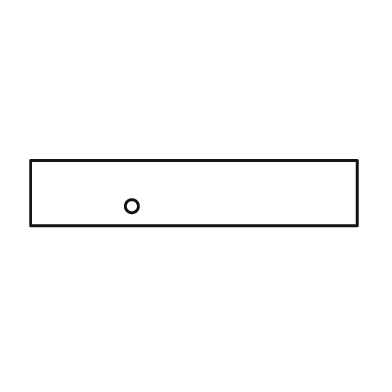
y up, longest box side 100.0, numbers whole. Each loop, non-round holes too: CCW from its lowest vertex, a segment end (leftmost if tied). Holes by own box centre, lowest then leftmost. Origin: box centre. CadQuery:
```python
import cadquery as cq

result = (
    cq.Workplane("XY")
    .moveTo(-50.0, -10.0)
    .lineTo(50.0, -10.0)
    .lineTo(50.0, 10.0)
    .lineTo(-50.0, 10.0)
    .close()
    .moveTo(-19.0, -4.0)
    .circle(2.0)
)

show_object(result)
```